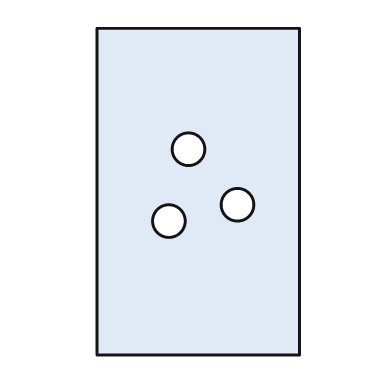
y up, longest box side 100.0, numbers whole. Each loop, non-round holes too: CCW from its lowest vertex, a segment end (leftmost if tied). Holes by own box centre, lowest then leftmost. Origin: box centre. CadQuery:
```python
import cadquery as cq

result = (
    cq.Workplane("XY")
    .moveTo(-31.0, -50.0)
    .lineTo(31.0, -50.0)
    .lineTo(31.0, 50.0)
    .lineTo(-31.0, 50.0)
    .close()
    .moveTo(-9.0, -9.0)
    .circle(5.0)
    .moveTo(12.0, -4.0)
    .circle(5.0)
    .moveTo(-3.0, 13.0)
    .circle(5.0)
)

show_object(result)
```